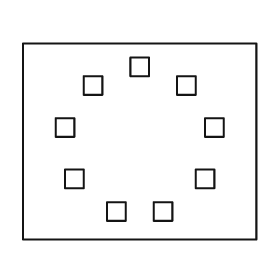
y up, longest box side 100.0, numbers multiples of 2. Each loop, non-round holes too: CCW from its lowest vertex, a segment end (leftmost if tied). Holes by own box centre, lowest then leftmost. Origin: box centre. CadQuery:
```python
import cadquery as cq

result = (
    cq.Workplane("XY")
    .moveTo(-50.0, -42.0)
    .lineTo(50.0, -42.0)
    .lineTo(50.0, 42.0)
    .lineTo(-50.0, 42.0)
    .close()
    .moveTo(-14.0, -34.0)
    .lineTo(-6.0, -34.0)
    .lineTo(-6.0, -26.0)
    .lineTo(-14.0, -26.0)
    .close()
    .moveTo(6.0, -34.0)
    .lineTo(14.0, -34.0)
    .lineTo(14.0, -26.0)
    .lineTo(6.0, -26.0)
    .close()
    .moveTo(-32.0, -20.0)
    .lineTo(-24.0, -20.0)
    .lineTo(-24.0, -12.0)
    .lineTo(-32.0, -12.0)
    .close()
    .moveTo(24.0, -20.0)
    .lineTo(32.0, -20.0)
    .lineTo(32.0, -12.0)
    .lineTo(24.0, -12.0)
    .close()
    .moveTo(-36.0, 2.0)
    .lineTo(-28.0, 2.0)
    .lineTo(-28.0, 10.0)
    .lineTo(-36.0, 10.0)
    .close()
    .moveTo(28.0, 2.0)
    .lineTo(36.0, 2.0)
    .lineTo(36.0, 10.0)
    .lineTo(28.0, 10.0)
    .close()
    .moveTo(-24.0, 20.0)
    .lineTo(-16.0, 20.0)
    .lineTo(-16.0, 28.0)
    .lineTo(-24.0, 28.0)
    .close()
    .moveTo(16.0, 20.0)
    .lineTo(24.0, 20.0)
    .lineTo(24.0, 28.0)
    .lineTo(16.0, 28.0)
    .close()
    .moveTo(-4.0, 28.0)
    .lineTo(4.0, 28.0)
    .lineTo(4.0, 36.0)
    .lineTo(-4.0, 36.0)
    .close()
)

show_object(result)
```